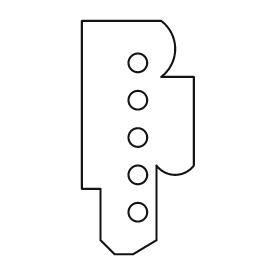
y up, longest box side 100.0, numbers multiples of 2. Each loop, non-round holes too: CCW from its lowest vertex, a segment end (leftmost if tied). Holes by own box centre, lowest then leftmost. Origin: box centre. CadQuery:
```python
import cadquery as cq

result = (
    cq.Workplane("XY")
    .moveTo(-10.0, -50.0)
    .lineTo(-2.0, -50.0)
    .lineTo(8.0, -44.0)
    .lineTo(8.0, -12.0)
    .threePointArc((16.0, -16.0), (24.0, -12.0))
    .lineTo(24.0, 26.0)
    .lineTo(10.0, 26.0)
    .threePointArc((16.0, 38.0), (10.0, 50.0))
    .lineTo(-24.0, 50.0)
    .lineTo(-24.0, -22.0)
    .lineTo(-16.0, -22.0)
    .lineTo(-16.0, -44.0)
    .close()
    .moveTo(0.0, -32.0)
    .circle(4.0)
    .moveTo(0.0, -16.0)
    .circle(4.0)
    .moveTo(0.0, 0.0)
    .circle(4.0)
    .moveTo(0.0, 16.0)
    .circle(4.0)
    .moveTo(0.0, 32.0)
    .circle(4.0)
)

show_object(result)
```